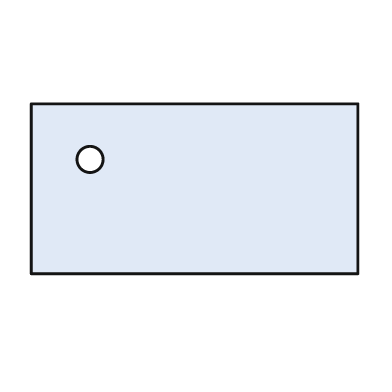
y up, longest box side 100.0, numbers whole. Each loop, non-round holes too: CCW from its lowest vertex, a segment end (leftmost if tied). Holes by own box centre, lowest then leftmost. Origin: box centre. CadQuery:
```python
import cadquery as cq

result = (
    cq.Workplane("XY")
    .moveTo(-50.0, -26.0)
    .lineTo(50.0, -26.0)
    .lineTo(50.0, 26.0)
    .lineTo(-50.0, 26.0)
    .close()
    .moveTo(-32.0, 9.0)
    .circle(4.0)
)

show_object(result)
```